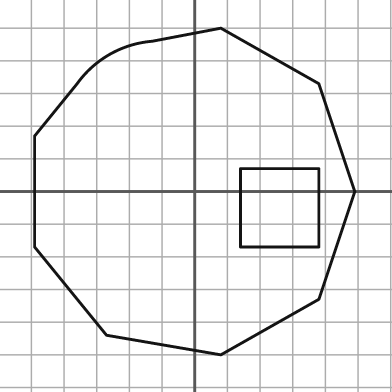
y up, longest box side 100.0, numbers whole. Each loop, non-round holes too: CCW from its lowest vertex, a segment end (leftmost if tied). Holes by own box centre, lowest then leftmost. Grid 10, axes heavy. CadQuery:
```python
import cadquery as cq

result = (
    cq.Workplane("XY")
    .moveTo(8.0, -50.0)
    .lineTo(38.0, -33.0)
    .lineTo(49.0, 0.0)
    .lineTo(38.0, 33.0)
    .lineTo(8.0, 50.0)
    .lineTo(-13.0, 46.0)
    .threePointArc((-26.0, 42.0), (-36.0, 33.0))
    .lineTo(-49.0, 17.0)
    .lineTo(-49.0, -17.0)
    .lineTo(-27.0, -44.0)
    .close()
    .moveTo(14.0, -17.0)
    .lineTo(38.0, -17.0)
    .lineTo(38.0, 7.0)
    .lineTo(14.0, 7.0)
    .close()
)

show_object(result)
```